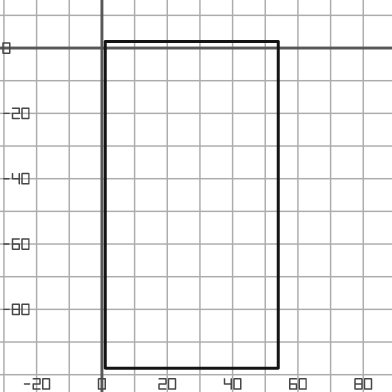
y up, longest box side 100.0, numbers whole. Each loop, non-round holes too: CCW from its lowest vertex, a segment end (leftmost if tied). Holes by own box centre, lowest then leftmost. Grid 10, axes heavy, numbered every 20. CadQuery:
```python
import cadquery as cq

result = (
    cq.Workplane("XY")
    .moveTo(1.0, -98.0)
    .lineTo(54.0, -98.0)
    .lineTo(54.0, 2.0)
    .lineTo(1.0, 2.0)
    .close()
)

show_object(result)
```